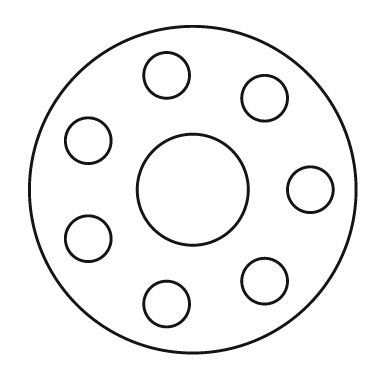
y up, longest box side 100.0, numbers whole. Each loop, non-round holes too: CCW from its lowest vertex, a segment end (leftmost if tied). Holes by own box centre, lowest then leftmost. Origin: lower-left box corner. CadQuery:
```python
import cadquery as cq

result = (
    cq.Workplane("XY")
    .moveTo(50.0, 50.0)
    .circle(50.0)
    .moveTo(42.0, 15.0)
    .circle(7.0)
    .moveTo(72.0, 22.0)
    .circle(7.0)
    .moveTo(18.0, 35.0)
    .circle(7.0)
    .moveTo(50.0, 50.0)
    .circle(17.0)
    .moveTo(86.0, 50.0)
    .circle(7.0)
    .moveTo(18.0, 65.0)
    .circle(7.0)
    .moveTo(72.0, 78.0)
    .circle(7.0)
    .moveTo(42.0, 85.0)
    .circle(7.0)
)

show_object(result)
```